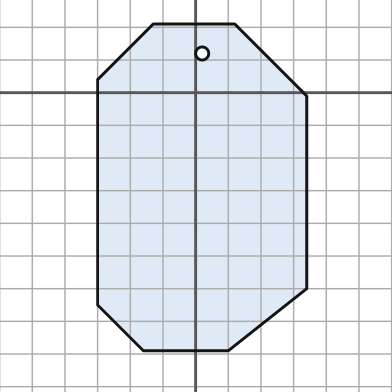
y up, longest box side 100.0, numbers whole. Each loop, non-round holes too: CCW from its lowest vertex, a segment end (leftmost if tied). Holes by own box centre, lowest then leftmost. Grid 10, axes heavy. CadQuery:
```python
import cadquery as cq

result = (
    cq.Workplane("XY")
    .moveTo(-16.0, -79.0)
    .lineTo(10.0, -79.0)
    .lineTo(34.0, -60.0)
    .lineTo(34.0, -1.0)
    .lineTo(12.0, 21.0)
    .lineTo(-13.0, 21.0)
    .lineTo(-30.0, 4.0)
    .lineTo(-30.0, -65.0)
    .close()
    .moveTo(2.0, 12.0)
    .circle(2.0)
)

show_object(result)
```